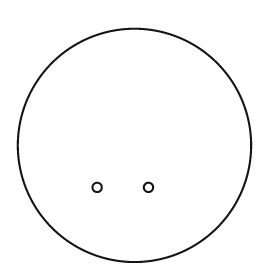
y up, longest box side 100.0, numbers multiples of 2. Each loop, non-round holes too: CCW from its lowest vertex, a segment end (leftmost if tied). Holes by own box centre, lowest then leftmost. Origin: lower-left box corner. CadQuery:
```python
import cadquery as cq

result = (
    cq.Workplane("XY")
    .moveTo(50.0, 50.0)
    .circle(50.0)
    .moveTo(34.0, 32.0)
    .circle(2.0)
    .moveTo(56.0, 32.0)
    .circle(2.0)
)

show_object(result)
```